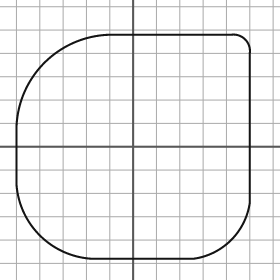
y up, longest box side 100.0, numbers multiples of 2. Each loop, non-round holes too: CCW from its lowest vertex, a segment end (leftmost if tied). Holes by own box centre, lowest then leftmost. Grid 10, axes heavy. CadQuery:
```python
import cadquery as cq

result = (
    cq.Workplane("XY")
    .moveTo(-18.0, -48.0)
    .lineTo(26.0, -48.0)
    .threePointArc((42.0, -40.0), (50.0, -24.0))
    .lineTo(50.0, 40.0)
    .threePointArc((48.0, 46.0), (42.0, 48.0))
    .lineTo(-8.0, 48.0)
    .threePointArc((-38.0, 36.0), (-50.0, 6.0))
    .lineTo(-50.0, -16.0)
    .threePointArc((-40.0, -38.0), (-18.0, -48.0))
    .close()
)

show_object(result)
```